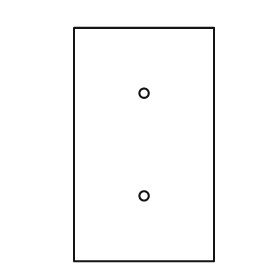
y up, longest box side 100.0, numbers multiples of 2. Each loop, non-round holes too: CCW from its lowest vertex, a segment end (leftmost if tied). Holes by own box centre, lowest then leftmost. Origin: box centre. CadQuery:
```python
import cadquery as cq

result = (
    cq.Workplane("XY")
    .moveTo(-30.0, -50.0)
    .lineTo(30.0, -50.0)
    .lineTo(30.0, 50.0)
    .lineTo(-30.0, 50.0)
    .close()
    .moveTo(0.0, -22.0)
    .circle(2.0)
    .moveTo(0.0, 22.0)
    .circle(2.0)
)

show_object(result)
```